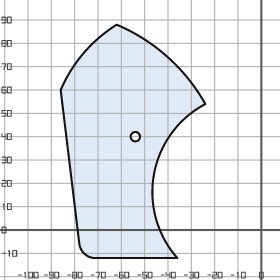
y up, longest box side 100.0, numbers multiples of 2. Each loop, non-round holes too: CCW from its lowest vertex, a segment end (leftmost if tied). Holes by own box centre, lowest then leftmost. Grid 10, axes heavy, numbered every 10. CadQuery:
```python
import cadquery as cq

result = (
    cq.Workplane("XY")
    .moveTo(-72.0, -12.0)
    .lineTo(-36.0, -12.0)
    .threePointArc((-46.0, 24.0), (-24.0, 54.0))
    .threePointArc((-40.0, 74.0), (-62.0, 88.0))
    .threePointArc((-76.0, 76.0), (-86.0, 60.0))
    .lineTo(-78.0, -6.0)
    .threePointArc((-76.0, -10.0), (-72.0, -12.0))
    .close()
    .moveTo(-54.0, 40.0)
    .circle(2.0)
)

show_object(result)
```